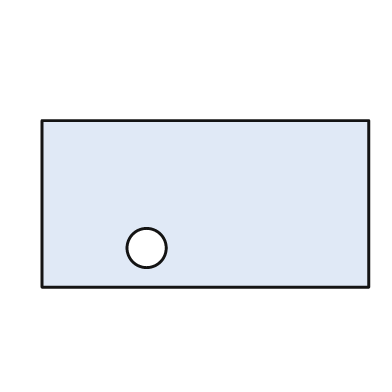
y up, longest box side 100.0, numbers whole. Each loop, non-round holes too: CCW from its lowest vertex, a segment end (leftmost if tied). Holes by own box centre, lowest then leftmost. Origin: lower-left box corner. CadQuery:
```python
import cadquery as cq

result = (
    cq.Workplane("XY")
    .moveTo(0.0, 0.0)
    .lineTo(100.0, 0.0)
    .lineTo(100.0, 51.0)
    .lineTo(0.0, 51.0)
    .close()
    .moveTo(32.0, 12.0)
    .circle(6.0)
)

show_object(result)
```